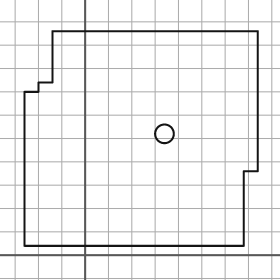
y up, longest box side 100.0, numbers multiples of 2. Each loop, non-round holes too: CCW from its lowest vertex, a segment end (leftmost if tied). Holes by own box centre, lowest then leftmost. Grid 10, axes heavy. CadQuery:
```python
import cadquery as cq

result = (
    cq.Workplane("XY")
    .moveTo(-26.0, 4.0)
    .lineTo(68.0, 4.0)
    .lineTo(68.0, 36.0)
    .lineTo(74.0, 36.0)
    .lineTo(74.0, 96.0)
    .lineTo(-14.0, 96.0)
    .lineTo(-14.0, 74.0)
    .lineTo(-20.0, 74.0)
    .lineTo(-20.0, 70.0)
    .lineTo(-26.0, 70.0)
    .close()
    .moveTo(34.0, 52.0)
    .circle(4.0)
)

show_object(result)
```